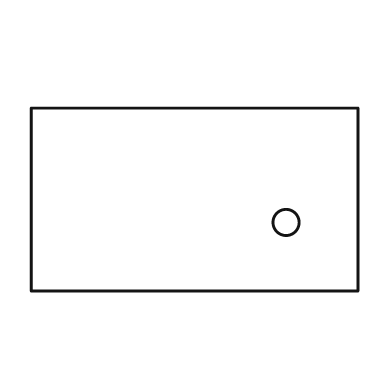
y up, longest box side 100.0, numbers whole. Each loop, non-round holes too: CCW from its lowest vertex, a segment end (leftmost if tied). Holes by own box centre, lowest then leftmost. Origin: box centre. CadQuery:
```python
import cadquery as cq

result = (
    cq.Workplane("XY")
    .moveTo(-50.0, -28.0)
    .lineTo(50.0, -28.0)
    .lineTo(50.0, 28.0)
    .lineTo(-50.0, 28.0)
    .close()
    .moveTo(28.0, -7.0)
    .circle(4.0)
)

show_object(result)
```